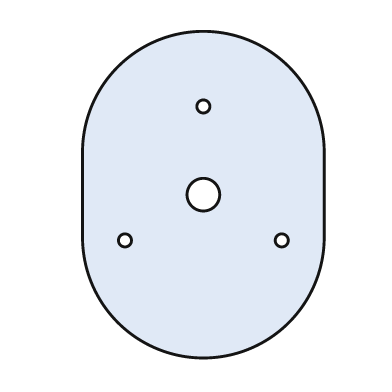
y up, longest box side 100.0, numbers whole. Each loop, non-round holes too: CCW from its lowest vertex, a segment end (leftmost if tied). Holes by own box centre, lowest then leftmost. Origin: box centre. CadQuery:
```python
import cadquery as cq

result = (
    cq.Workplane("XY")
    .moveTo(-37.0, -13.0)
    .threePointArc((0.0, -50.0), (37.0, -13.0))
    .lineTo(37.0, 13.0)
    .threePointArc((0.0, 50.0), (-37.0, 13.0))
    .close()
    .moveTo(-24.0, -14.0)
    .circle(2.0)
    .moveTo(24.0, -14.0)
    .circle(2.0)
    .moveTo(0.0, 0.0)
    .circle(5.0)
    .moveTo(0.0, 27.0)
    .circle(2.0)
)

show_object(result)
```